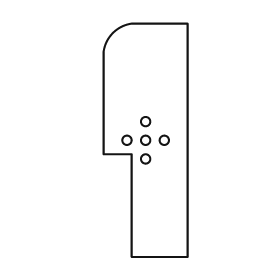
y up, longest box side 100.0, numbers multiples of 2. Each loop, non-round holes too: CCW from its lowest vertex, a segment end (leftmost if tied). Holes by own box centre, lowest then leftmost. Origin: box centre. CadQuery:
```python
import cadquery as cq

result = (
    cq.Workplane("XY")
    .moveTo(-6.0, -50.0)
    .lineTo(18.0, -50.0)
    .lineTo(18.0, 50.0)
    .lineTo(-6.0, 50.0)
    .threePointArc((-14.0, 46.0), (-18.0, 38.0))
    .lineTo(-18.0, -6.0)
    .lineTo(-6.0, -6.0)
    .close()
    .moveTo(0.0, -8.0)
    .circle(2.0)
    .moveTo(-8.0, 0.0)
    .circle(2.0)
    .moveTo(0.0, 0.0)
    .circle(2.0)
    .moveTo(8.0, 0.0)
    .circle(2.0)
    .moveTo(0.0, 8.0)
    .circle(2.0)
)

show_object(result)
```